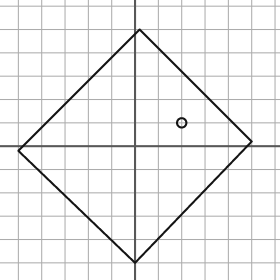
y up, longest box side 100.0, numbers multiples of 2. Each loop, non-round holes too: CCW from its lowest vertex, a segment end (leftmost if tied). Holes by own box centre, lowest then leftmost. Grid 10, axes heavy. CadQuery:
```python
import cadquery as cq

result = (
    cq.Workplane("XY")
    .moveTo(0.0, -50.0)
    .lineTo(50.0, 2.0)
    .lineTo(2.0, 50.0)
    .lineTo(-50.0, -2.0)
    .close()
    .moveTo(20.0, 10.0)
    .circle(2.0)
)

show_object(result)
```